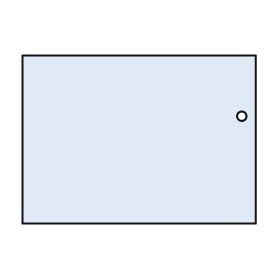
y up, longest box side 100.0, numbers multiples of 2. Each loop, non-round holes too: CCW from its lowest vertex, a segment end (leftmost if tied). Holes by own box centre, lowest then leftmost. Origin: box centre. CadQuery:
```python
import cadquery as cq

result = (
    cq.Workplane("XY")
    .moveTo(-50.0, -36.0)
    .lineTo(50.0, -36.0)
    .lineTo(50.0, 36.0)
    .lineTo(-50.0, 36.0)
    .close()
    .moveTo(44.0, 10.0)
    .circle(2.0)
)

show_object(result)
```